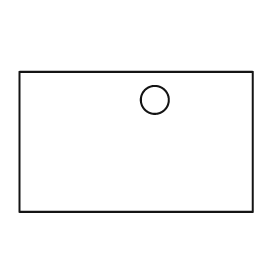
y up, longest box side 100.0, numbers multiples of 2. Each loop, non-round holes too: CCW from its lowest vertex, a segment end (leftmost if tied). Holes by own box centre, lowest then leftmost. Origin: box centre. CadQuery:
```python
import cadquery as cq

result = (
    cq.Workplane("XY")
    .moveTo(-50.0, -30.0)
    .lineTo(50.0, -30.0)
    .lineTo(50.0, 30.0)
    .lineTo(-50.0, 30.0)
    .close()
    .moveTo(8.0, 18.0)
    .circle(6.0)
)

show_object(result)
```